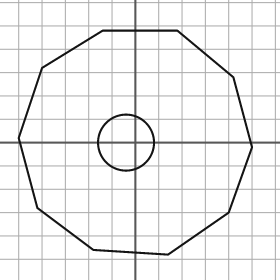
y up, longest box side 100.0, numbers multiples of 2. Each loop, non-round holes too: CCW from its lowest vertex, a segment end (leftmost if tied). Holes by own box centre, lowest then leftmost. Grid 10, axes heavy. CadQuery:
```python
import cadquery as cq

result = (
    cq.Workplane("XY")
    .moveTo(14.0, -48.0)
    .lineTo(40.0, -30.0)
    .lineTo(50.0, -2.0)
    .lineTo(42.0, 28.0)
    .lineTo(18.0, 48.0)
    .lineTo(-14.0, 48.0)
    .lineTo(-40.0, 32.0)
    .lineTo(-50.0, 2.0)
    .lineTo(-42.0, -28.0)
    .lineTo(-18.0, -46.0)
    .close()
    .moveTo(-4.0, 0.0)
    .circle(12.0)
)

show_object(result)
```